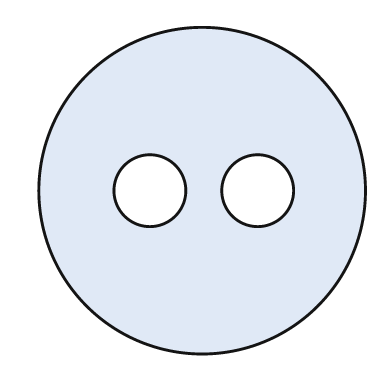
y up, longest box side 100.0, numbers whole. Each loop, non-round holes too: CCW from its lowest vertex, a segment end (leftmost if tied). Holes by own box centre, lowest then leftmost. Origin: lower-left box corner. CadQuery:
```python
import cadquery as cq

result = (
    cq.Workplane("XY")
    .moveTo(50.0, 50.0)
    .circle(50.0)
    .moveTo(34.0, 50.0)
    .circle(11.0)
    .moveTo(67.0, 50.0)
    .circle(11.0)
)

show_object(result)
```